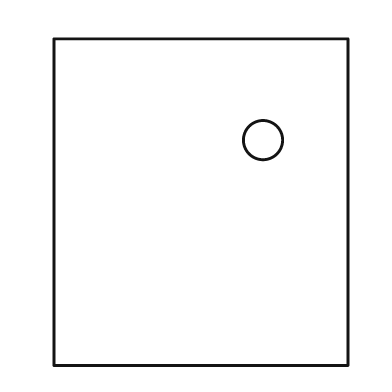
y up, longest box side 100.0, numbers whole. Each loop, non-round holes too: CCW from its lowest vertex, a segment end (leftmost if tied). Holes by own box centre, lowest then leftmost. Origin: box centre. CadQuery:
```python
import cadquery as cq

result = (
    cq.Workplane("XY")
    .moveTo(-45.0, -50.0)
    .lineTo(45.0, -50.0)
    .lineTo(45.0, 50.0)
    .lineTo(-45.0, 50.0)
    .close()
    .moveTo(19.0, 19.0)
    .circle(6.0)
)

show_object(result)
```